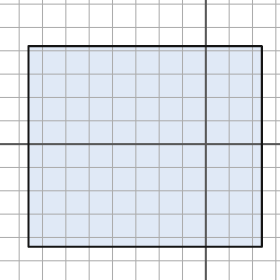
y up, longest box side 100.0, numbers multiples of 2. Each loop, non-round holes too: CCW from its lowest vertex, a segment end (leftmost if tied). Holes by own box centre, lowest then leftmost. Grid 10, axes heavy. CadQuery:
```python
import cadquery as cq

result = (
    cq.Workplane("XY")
    .moveTo(-76.0, -44.0)
    .lineTo(24.0, -44.0)
    .lineTo(24.0, 42.0)
    .lineTo(-76.0, 42.0)
    .close()
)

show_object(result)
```